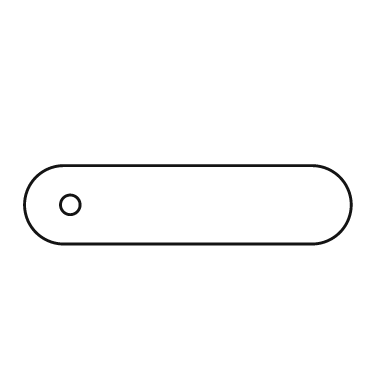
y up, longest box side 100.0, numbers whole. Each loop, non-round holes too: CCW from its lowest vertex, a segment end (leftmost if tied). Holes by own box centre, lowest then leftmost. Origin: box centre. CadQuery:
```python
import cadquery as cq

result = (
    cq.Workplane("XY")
    .moveTo(-38.0, -12.0)
    .lineTo(38.0, -12.0)
    .threePointArc((50.0, 0.0), (38.0, 12.0))
    .lineTo(-38.0, 12.0)
    .threePointArc((-50.0, 0.0), (-38.0, -12.0))
    .close()
    .moveTo(-36.0, 0.0)
    .circle(3.0)
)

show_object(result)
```